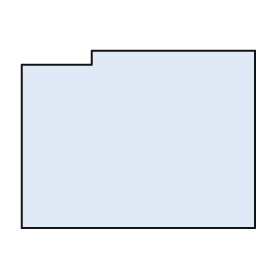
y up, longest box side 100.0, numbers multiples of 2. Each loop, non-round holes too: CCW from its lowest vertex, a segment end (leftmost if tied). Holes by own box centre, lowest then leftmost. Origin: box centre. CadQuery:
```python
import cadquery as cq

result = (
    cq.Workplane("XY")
    .moveTo(-50.0, -38.0)
    .lineTo(50.0, -38.0)
    .lineTo(50.0, 38.0)
    .lineTo(-20.0, 38.0)
    .lineTo(-20.0, 32.0)
    .lineTo(-50.0, 32.0)
    .close()
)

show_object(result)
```